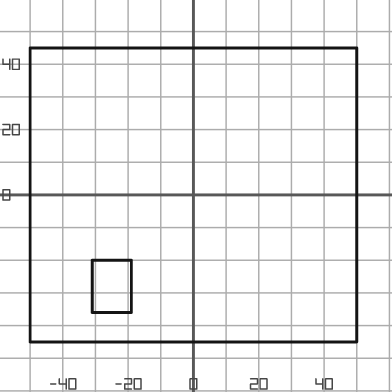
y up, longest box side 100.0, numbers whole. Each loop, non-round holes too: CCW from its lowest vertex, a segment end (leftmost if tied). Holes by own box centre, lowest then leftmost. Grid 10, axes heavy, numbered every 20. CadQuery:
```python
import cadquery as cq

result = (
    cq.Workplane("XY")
    .moveTo(-50.0, -45.0)
    .lineTo(50.0, -45.0)
    .lineTo(50.0, 45.0)
    .lineTo(-50.0, 45.0)
    .close()
    .moveTo(-31.0, -36.0)
    .lineTo(-19.0, -36.0)
    .lineTo(-19.0, -20.0)
    .lineTo(-31.0, -20.0)
    .close()
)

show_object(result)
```